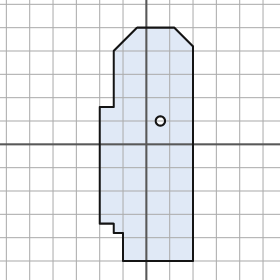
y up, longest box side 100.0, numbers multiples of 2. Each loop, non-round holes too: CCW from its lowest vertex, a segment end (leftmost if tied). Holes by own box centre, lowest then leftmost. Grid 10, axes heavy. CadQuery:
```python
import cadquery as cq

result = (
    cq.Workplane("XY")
    .moveTo(-10.0, -50.0)
    .lineTo(20.0, -50.0)
    .lineTo(20.0, 42.0)
    .lineTo(12.0, 50.0)
    .lineTo(-4.0, 50.0)
    .lineTo(-14.0, 40.0)
    .lineTo(-14.0, 16.0)
    .lineTo(-20.0, 16.0)
    .lineTo(-20.0, -34.0)
    .lineTo(-14.0, -34.0)
    .lineTo(-14.0, -38.0)
    .lineTo(-10.0, -38.0)
    .close()
    .moveTo(6.0, 10.0)
    .circle(2.0)
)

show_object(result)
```